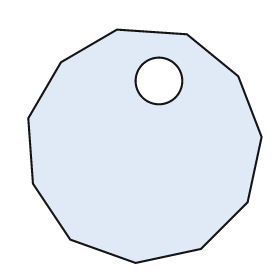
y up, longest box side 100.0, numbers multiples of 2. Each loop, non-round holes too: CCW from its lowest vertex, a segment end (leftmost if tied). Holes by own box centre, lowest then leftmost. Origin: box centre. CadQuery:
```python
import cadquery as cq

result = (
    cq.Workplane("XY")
    .moveTo(-4.0, -50.0)
    .lineTo(24.0, -44.0)
    .lineTo(44.0, -24.0)
    .lineTo(50.0, 4.0)
    .lineTo(40.0, 30.0)
    .lineTo(18.0, 48.0)
    .lineTo(-12.0, 50.0)
    .lineTo(-36.0, 36.0)
    .lineTo(-50.0, 12.0)
    .lineTo(-48.0, -16.0)
    .lineTo(-32.0, -40.0)
    .close()
    .moveTo(6.0, 28.0)
    .circle(10.0)
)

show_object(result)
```